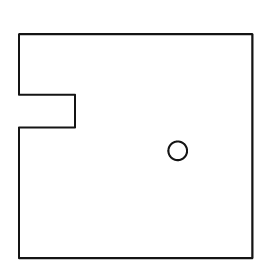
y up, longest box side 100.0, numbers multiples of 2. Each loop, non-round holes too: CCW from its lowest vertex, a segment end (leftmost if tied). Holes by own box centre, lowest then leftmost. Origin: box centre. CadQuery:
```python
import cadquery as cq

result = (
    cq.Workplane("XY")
    .moveTo(-50.0, -48.0)
    .lineTo(50.0, -48.0)
    .lineTo(50.0, 48.0)
    .lineTo(-50.0, 48.0)
    .lineTo(-50.0, 22.0)
    .lineTo(-26.0, 22.0)
    .lineTo(-26.0, 8.0)
    .lineTo(-50.0, 8.0)
    .close()
    .moveTo(18.0, -2.0)
    .circle(4.0)
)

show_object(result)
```